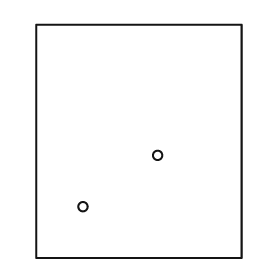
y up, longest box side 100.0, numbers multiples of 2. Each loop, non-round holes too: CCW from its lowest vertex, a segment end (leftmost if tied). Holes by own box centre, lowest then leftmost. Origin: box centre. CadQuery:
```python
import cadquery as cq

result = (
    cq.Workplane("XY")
    .moveTo(-44.0, -50.0)
    .lineTo(44.0, -50.0)
    .lineTo(44.0, 50.0)
    .lineTo(-44.0, 50.0)
    .close()
    .moveTo(-24.0, -28.0)
    .circle(2.0)
    .moveTo(8.0, -6.0)
    .circle(2.0)
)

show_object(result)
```